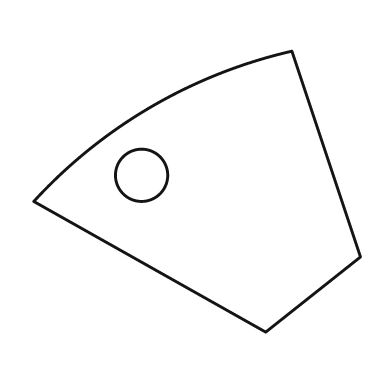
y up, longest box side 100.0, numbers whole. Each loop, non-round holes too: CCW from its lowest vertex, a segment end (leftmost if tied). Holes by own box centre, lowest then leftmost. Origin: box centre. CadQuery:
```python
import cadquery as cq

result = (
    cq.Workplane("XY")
    .moveTo(21.0, -43.0)
    .lineTo(50.0, -20.0)
    .lineTo(29.0, 43.0)
    .threePointArc((-14.0, 26.0), (-50.0, -3.0))
    .close()
    .moveTo(-17.0, 5.0)
    .circle(8.0)
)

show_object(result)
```